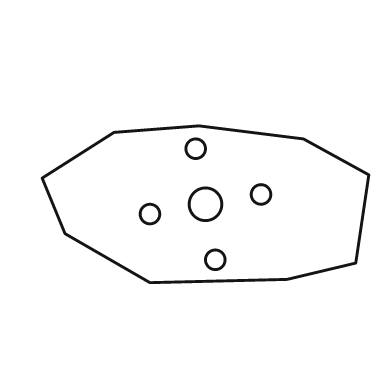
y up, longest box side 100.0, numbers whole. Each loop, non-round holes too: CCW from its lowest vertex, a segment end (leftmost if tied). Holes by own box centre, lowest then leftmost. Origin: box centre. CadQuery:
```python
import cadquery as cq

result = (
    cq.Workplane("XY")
    .moveTo(-17.0, -24.0)
    .lineTo(25.0, -23.0)
    .lineTo(46.0, -18.0)
    .lineTo(50.0, 9.0)
    .lineTo(30.0, 20.0)
    .lineTo(-2.0, 24.0)
    .lineTo(-28.0, 22.0)
    .lineTo(-50.0, 8.0)
    .lineTo(-43.0, -9.0)
    .close()
    .moveTo(3.0, -17.0)
    .circle(3.0)
    .moveTo(-17.0, -3.0)
    .circle(3.0)
    .moveTo(0.0, 0.0)
    .circle(5.0)
    .moveTo(17.0, 3.0)
    .circle(3.0)
    .moveTo(-3.0, 17.0)
    .circle(3.0)
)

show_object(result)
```